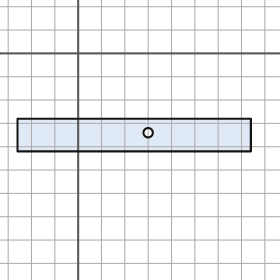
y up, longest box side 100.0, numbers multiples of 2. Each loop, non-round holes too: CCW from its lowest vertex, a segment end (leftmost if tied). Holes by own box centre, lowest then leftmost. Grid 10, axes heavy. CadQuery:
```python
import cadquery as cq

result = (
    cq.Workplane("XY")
    .moveTo(-26.0, -42.0)
    .lineTo(74.0, -42.0)
    .lineTo(74.0, -28.0)
    .lineTo(-26.0, -28.0)
    .close()
    .moveTo(30.0, -34.0)
    .circle(2.0)
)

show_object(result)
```